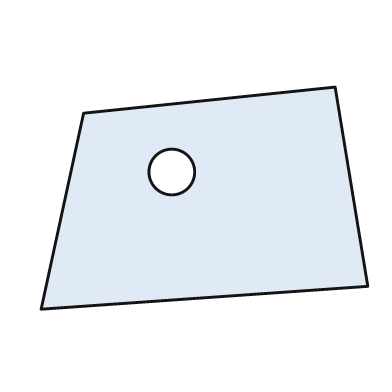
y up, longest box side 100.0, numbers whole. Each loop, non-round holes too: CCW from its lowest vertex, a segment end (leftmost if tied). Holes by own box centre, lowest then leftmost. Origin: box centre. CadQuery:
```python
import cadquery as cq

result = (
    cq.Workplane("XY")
    .moveTo(-50.0, -34.0)
    .lineTo(50.0, -27.0)
    .lineTo(40.0, 34.0)
    .lineTo(-37.0, 26.0)
    .close()
    .moveTo(-10.0, 8.0)
    .circle(7.0)
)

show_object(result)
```